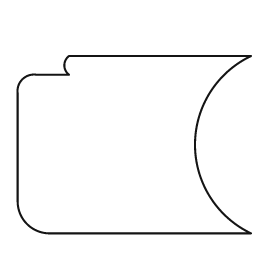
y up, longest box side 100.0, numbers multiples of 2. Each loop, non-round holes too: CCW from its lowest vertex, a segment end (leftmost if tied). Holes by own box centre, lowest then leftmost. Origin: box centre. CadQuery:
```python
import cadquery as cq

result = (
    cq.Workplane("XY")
    .moveTo(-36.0, -38.0)
    .lineTo(50.0, -38.0)
    .threePointArc((26.0, 0.0), (50.0, 38.0))
    .lineTo(-28.0, 38.0)
    .threePointArc((-30.0, 34.0), (-28.0, 30.0))
    .lineTo(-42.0, 30.0)
    .threePointArc((-48.0, 28.0), (-50.0, 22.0))
    .lineTo(-50.0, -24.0)
    .threePointArc((-46.0, -34.0), (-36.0, -38.0))
    .close()
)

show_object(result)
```